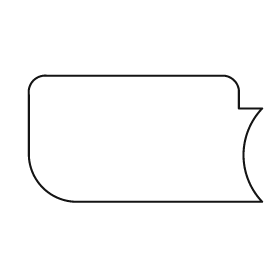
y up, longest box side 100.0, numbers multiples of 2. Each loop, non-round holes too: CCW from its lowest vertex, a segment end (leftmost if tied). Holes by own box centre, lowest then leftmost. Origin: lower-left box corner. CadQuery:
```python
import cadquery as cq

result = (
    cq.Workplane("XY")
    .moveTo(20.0, 0.0)
    .lineTo(100.0, 0.0)
    .threePointArc((92.0, 20.0), (100.0, 40.0))
    .lineTo(90.0, 40.0)
    .lineTo(90.0, 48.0)
    .threePointArc((88.0, 52.0), (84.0, 54.0))
    .lineTo(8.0, 54.0)
    .threePointArc((2.0, 52.0), (0.0, 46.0))
    .lineTo(0.0, 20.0)
    .threePointArc((6.0, 6.0), (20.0, 0.0))
    .close()
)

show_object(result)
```